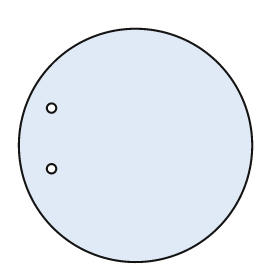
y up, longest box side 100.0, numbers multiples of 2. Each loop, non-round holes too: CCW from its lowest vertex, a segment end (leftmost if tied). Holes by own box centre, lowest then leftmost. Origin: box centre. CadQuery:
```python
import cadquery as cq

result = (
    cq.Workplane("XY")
    .moveTo(0.0, 0.0)
    .circle(50.0)
    .moveTo(-36.0, -10.0)
    .circle(2.0)
    .moveTo(-36.0, 16.0)
    .circle(2.0)
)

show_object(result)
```